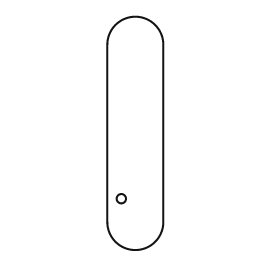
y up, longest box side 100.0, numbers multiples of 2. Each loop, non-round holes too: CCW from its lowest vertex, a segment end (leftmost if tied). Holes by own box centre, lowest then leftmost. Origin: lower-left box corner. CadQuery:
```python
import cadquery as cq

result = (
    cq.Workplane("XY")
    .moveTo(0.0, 12.0)
    .threePointArc((12.0, 0.0), (24.0, 12.0))
    .lineTo(24.0, 88.0)
    .threePointArc((12.0, 100.0), (0.0, 88.0))
    .close()
    .moveTo(6.0, 22.0)
    .circle(2.0)
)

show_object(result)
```